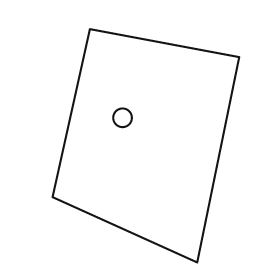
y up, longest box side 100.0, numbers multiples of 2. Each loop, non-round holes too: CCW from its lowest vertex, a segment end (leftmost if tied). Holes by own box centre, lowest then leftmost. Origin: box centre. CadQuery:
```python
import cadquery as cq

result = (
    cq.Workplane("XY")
    .moveTo(22.0, -50.0)
    .lineTo(40.0, 38.0)
    .lineTo(-24.0, 50.0)
    .lineTo(-40.0, -22.0)
    .close()
    .moveTo(-10.0, 12.0)
    .circle(4.0)
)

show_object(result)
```